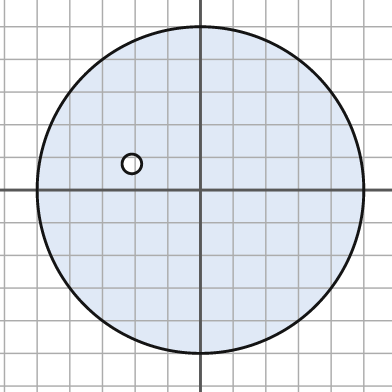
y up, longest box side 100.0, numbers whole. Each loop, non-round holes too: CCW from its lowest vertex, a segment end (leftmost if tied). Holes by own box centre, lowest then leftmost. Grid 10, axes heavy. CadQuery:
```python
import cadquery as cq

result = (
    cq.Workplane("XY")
    .moveTo(0.0, 0.0)
    .circle(50.0)
    .moveTo(-21.0, 8.0)
    .circle(3.0)
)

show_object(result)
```